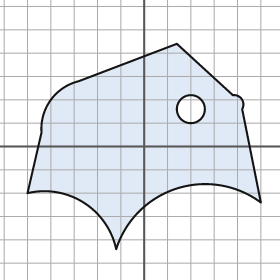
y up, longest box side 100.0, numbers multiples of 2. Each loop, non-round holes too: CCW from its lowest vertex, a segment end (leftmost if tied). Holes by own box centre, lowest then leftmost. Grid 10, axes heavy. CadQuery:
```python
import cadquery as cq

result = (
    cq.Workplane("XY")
    .moveTo(-12.0, -44.0)
    .threePointArc((14.0, -18.0), (50.0, -24.0))
    .lineTo(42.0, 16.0)
    .threePointArc((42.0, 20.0), (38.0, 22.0))
    .lineTo(14.0, 44.0)
    .lineTo(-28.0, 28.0)
    .threePointArc((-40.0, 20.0), (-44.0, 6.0))
    .lineTo(-50.0, -20.0)
    .threePointArc((-26.0, -24.0), (-12.0, -44.0))
    .close()
    .moveTo(20.0, 16.0)
    .circle(6.0)
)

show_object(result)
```